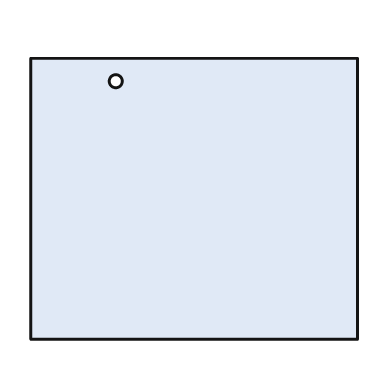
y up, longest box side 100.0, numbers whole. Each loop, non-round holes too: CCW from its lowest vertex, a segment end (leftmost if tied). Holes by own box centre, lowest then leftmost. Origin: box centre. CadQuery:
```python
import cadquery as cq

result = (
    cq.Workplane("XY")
    .moveTo(-50.0, -43.0)
    .lineTo(50.0, -43.0)
    .lineTo(50.0, 43.0)
    .lineTo(-50.0, 43.0)
    .close()
    .moveTo(-24.0, 36.0)
    .circle(2.0)
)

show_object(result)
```